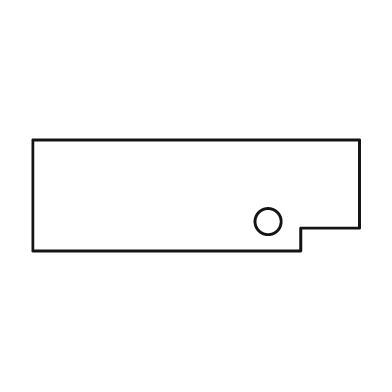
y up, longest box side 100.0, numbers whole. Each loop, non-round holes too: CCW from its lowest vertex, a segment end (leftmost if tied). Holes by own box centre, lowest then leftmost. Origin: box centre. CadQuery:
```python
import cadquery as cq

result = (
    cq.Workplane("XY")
    .moveTo(-50.0, -17.0)
    .lineTo(32.0, -17.0)
    .lineTo(32.0, -10.0)
    .lineTo(50.0, -10.0)
    .lineTo(50.0, 17.0)
    .lineTo(-50.0, 17.0)
    .close()
    .moveTo(22.0, -8.0)
    .circle(4.0)
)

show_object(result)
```